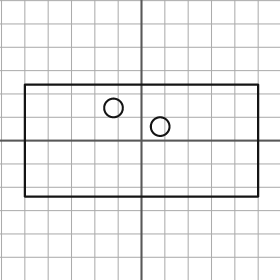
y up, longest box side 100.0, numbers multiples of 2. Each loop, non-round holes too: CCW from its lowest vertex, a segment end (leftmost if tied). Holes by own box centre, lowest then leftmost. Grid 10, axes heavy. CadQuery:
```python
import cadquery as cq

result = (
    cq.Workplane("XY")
    .moveTo(-50.0, -24.0)
    .lineTo(50.0, -24.0)
    .lineTo(50.0, 24.0)
    .lineTo(-50.0, 24.0)
    .close()
    .moveTo(8.0, 6.0)
    .circle(4.0)
    .moveTo(-12.0, 14.0)
    .circle(4.0)
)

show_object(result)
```